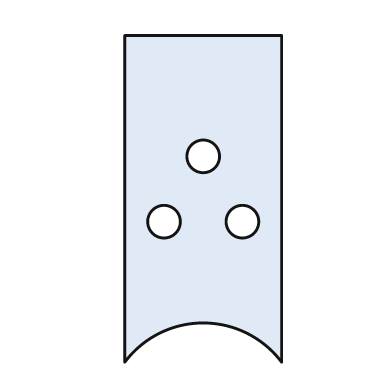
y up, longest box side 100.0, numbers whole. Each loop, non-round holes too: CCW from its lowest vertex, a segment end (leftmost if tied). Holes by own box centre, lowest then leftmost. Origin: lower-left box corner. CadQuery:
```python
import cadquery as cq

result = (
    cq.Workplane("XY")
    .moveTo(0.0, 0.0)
    .threePointArc((24.0, 12.0), (48.0, 0.0))
    .lineTo(48.0, 100.0)
    .lineTo(0.0, 100.0)
    .close()
    .moveTo(12.0, 43.0)
    .circle(5.0)
    .moveTo(36.0, 43.0)
    .circle(5.0)
    .moveTo(24.0, 63.0)
    .circle(5.0)
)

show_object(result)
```